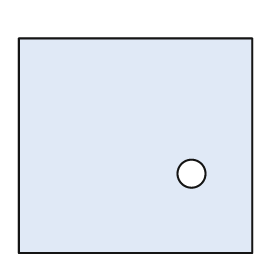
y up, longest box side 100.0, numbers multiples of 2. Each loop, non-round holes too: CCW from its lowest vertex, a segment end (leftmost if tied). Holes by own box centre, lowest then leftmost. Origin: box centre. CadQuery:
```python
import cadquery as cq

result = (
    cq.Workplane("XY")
    .moveTo(-50.0, -46.0)
    .lineTo(50.0, -46.0)
    .lineTo(50.0, 46.0)
    .lineTo(-50.0, 46.0)
    .close()
    .moveTo(24.0, -12.0)
    .circle(6.0)
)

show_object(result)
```